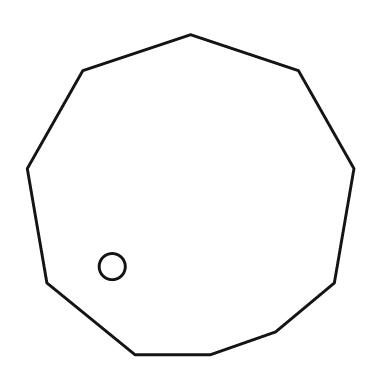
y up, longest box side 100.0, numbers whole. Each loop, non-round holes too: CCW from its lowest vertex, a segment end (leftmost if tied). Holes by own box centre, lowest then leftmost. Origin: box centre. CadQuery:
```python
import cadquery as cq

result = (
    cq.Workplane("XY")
    .moveTo(-17.0, -49.0)
    .lineTo(6.0, -49.0)
    .lineTo(26.0, -42.0)
    .lineTo(44.0, -27.0)
    .lineTo(50.0, 8.0)
    .lineTo(33.0, 38.0)
    .lineTo(0.0, 49.0)
    .lineTo(-33.0, 38.0)
    .lineTo(-50.0, 8.0)
    .lineTo(-44.0, -27.0)
    .close()
    .moveTo(-24.0, -22.0)
    .circle(4.0)
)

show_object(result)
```